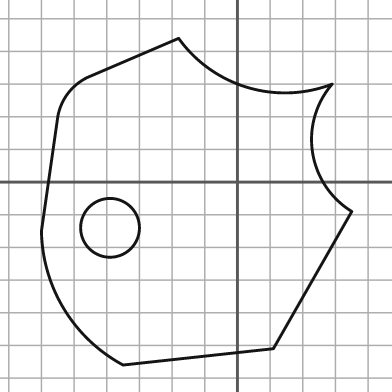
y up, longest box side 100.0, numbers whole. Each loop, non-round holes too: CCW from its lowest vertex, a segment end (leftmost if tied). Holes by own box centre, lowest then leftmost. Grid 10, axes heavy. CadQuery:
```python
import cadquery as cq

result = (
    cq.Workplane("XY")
    .moveTo(-35.0, -56.0)
    .lineTo(11.0, -51.0)
    .lineTo(35.0, -9.0)
    .threePointArc((23.0, 9.0), (29.0, 30.0))
    .threePointArc((3.0, 29.0), (-18.0, 44.0))
    .lineTo(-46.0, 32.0)
    .threePointArc((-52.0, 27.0), (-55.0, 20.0))
    .lineTo(-60.0, -15.0)
    .threePointArc((-53.0, -39.0), (-35.0, -56.0))
    .close()
    .moveTo(-39.0, -14.0)
    .circle(9.0)
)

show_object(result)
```